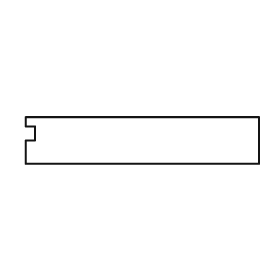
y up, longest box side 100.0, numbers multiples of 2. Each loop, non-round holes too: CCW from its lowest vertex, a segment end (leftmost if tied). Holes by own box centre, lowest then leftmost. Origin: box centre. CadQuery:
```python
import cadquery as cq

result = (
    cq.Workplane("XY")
    .moveTo(-50.0, -10.0)
    .lineTo(50.0, -10.0)
    .lineTo(50.0, 10.0)
    .lineTo(-50.0, 10.0)
    .lineTo(-50.0, 6.0)
    .lineTo(-46.0, 6.0)
    .lineTo(-46.0, 0.0)
    .lineTo(-50.0, 0.0)
    .close()
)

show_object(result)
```